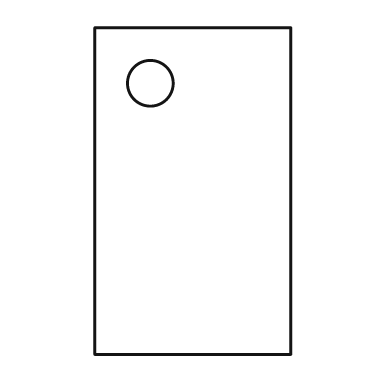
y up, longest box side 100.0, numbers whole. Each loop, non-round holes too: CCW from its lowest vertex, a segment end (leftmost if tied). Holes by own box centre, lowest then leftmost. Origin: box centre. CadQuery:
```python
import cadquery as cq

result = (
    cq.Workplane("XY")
    .moveTo(-30.0, -50.0)
    .lineTo(30.0, -50.0)
    .lineTo(30.0, 50.0)
    .lineTo(-30.0, 50.0)
    .close()
    .moveTo(-13.0, 33.0)
    .circle(7.0)
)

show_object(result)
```